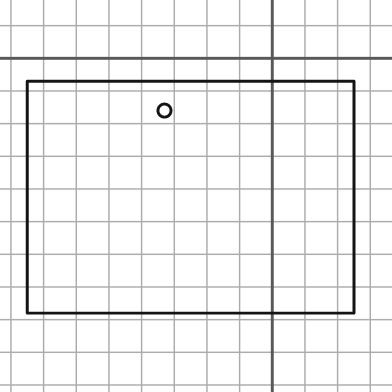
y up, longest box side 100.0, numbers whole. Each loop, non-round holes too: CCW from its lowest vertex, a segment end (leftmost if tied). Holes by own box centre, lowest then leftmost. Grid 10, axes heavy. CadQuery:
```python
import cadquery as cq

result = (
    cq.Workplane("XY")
    .moveTo(-75.0, -78.0)
    .lineTo(25.0, -78.0)
    .lineTo(25.0, -7.0)
    .lineTo(-75.0, -7.0)
    .close()
    .moveTo(-33.0, -16.0)
    .circle(2.0)
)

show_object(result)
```